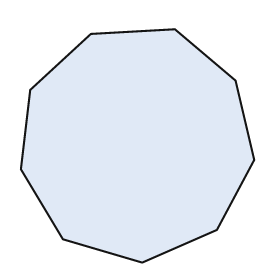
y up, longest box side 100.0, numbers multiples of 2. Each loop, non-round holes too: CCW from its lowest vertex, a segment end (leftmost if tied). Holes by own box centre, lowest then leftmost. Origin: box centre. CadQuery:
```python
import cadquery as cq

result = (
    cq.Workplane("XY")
    .moveTo(2.0, -50.0)
    .lineTo(34.0, -36.0)
    .lineTo(50.0, -6.0)
    .lineTo(42.0, 28.0)
    .lineTo(16.0, 50.0)
    .lineTo(-20.0, 48.0)
    .lineTo(-46.0, 24.0)
    .lineTo(-50.0, -10.0)
    .lineTo(-32.0, -40.0)
    .close()
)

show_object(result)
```